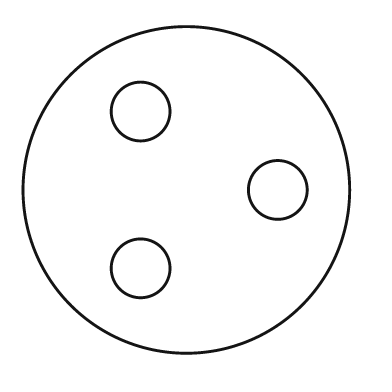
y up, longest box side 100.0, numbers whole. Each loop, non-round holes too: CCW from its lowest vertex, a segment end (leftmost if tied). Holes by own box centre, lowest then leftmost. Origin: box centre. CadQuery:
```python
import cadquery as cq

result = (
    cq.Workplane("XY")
    .moveTo(0.0, 0.0)
    .circle(50.0)
    .moveTo(-14.0, -24.0)
    .circle(9.0)
    .moveTo(28.0, 0.0)
    .circle(9.0)
    .moveTo(-14.0, 24.0)
    .circle(9.0)
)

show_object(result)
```